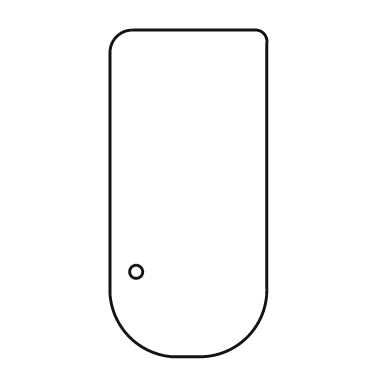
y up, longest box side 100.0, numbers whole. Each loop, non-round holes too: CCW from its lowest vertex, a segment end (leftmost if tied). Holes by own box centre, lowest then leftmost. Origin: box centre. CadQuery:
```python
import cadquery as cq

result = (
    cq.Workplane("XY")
    .moveTo(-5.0, -50.0)
    .lineTo(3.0, -50.0)
    .threePointArc((18.0, -44.0), (24.0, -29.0))
    .lineTo(24.0, 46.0)
    .threePointArc((23.0, 49.0), (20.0, 50.0))
    .lineTo(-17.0, 50.0)
    .threePointArc((-22.0, 48.0), (-24.0, 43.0))
    .lineTo(-24.0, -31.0)
    .threePointArc((-18.0, -44.0), (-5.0, -50.0))
    .close()
    .moveTo(-16.0, -24.0)
    .circle(2.0)
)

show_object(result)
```